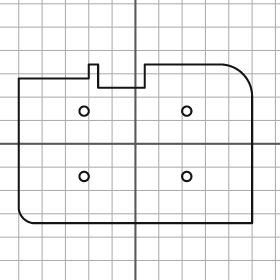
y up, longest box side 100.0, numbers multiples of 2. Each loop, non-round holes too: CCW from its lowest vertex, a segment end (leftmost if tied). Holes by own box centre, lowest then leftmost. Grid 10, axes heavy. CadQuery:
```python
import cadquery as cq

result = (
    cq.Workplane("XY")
    .moveTo(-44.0, -34.0)
    .lineTo(50.0, -34.0)
    .lineTo(50.0, 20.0)
    .threePointArc((46.0, 30.0), (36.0, 34.0))
    .lineTo(4.0, 34.0)
    .lineTo(4.0, 24.0)
    .lineTo(-16.0, 24.0)
    .lineTo(-16.0, 34.0)
    .lineTo(-20.0, 34.0)
    .lineTo(-20.0, 28.0)
    .lineTo(-50.0, 28.0)
    .lineTo(-50.0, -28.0)
    .threePointArc((-48.0, -32.0), (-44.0, -34.0))
    .close()
    .moveTo(-22.0, -14.0)
    .circle(2.0)
    .moveTo(22.0, -14.0)
    .circle(2.0)
    .moveTo(-22.0, 14.0)
    .circle(2.0)
    .moveTo(22.0, 14.0)
    .circle(2.0)
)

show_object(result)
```